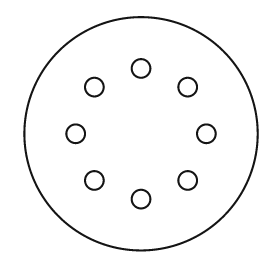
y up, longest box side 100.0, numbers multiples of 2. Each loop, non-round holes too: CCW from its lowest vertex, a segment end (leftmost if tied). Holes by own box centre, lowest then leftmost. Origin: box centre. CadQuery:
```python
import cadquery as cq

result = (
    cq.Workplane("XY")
    .moveTo(0.0, 0.0)
    .circle(50.0)
    .moveTo(0.0, -28.0)
    .circle(4.0)
    .moveTo(-20.0, -20.0)
    .circle(4.0)
    .moveTo(20.0, -20.0)
    .circle(4.0)
    .moveTo(-28.0, 0.0)
    .circle(4.0)
    .moveTo(28.0, 0.0)
    .circle(4.0)
    .moveTo(-20.0, 20.0)
    .circle(4.0)
    .moveTo(20.0, 20.0)
    .circle(4.0)
    .moveTo(0.0, 28.0)
    .circle(4.0)
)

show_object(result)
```